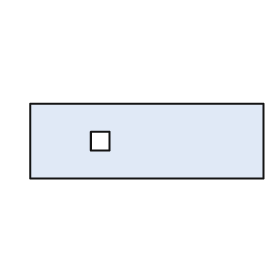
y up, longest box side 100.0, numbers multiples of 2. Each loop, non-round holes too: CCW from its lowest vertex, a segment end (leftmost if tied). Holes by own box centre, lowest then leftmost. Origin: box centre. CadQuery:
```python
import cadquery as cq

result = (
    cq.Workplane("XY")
    .moveTo(-50.0, -16.0)
    .lineTo(50.0, -16.0)
    .lineTo(50.0, 16.0)
    .lineTo(-50.0, 16.0)
    .close()
    .moveTo(-24.0, -4.0)
    .lineTo(-16.0, -4.0)
    .lineTo(-16.0, 4.0)
    .lineTo(-24.0, 4.0)
    .close()
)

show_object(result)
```